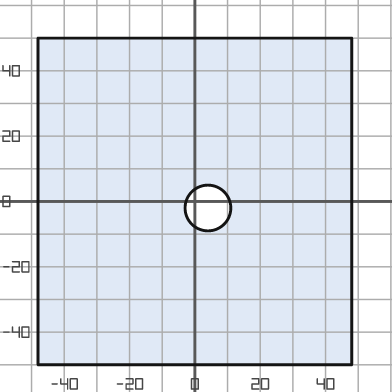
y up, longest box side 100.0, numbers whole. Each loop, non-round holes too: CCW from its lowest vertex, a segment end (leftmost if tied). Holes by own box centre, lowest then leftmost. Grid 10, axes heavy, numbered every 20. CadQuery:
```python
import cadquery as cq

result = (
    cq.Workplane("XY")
    .moveTo(-48.0, -50.0)
    .lineTo(48.0, -50.0)
    .lineTo(48.0, 50.0)
    .lineTo(-48.0, 50.0)
    .close()
    .moveTo(4.0, -2.0)
    .circle(7.0)
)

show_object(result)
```